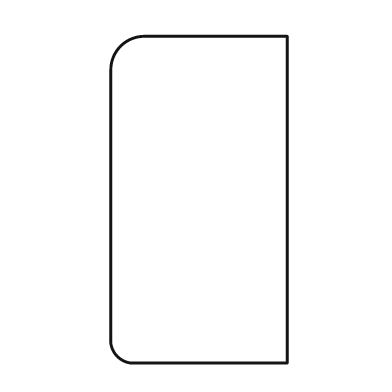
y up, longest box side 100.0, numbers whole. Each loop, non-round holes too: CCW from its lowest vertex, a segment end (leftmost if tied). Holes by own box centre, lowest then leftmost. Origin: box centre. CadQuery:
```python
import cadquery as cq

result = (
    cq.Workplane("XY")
    .moveTo(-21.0, -50.0)
    .lineTo(27.0, -50.0)
    .lineTo(27.0, 50.0)
    .lineTo(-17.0, 50.0)
    .threePointArc((-24.0, 47.0), (-27.0, 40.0))
    .lineTo(-27.0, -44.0)
    .threePointArc((-25.0, -48.0), (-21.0, -50.0))
    .close()
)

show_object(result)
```